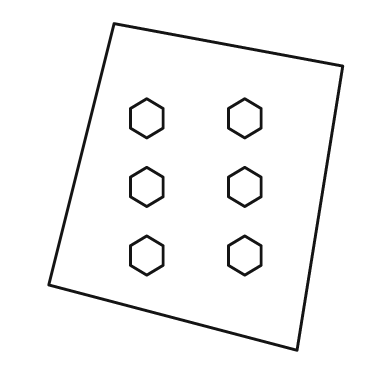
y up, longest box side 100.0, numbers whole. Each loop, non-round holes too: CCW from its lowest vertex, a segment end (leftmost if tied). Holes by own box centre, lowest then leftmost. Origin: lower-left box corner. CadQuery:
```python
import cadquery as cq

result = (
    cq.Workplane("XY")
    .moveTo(76.0, 0.0)
    .lineTo(90.0, 87.0)
    .lineTo(20.0, 100.0)
    .lineTo(0.0, 20.0)
    .close()
    .moveTo(30.0, 23.0)
    .lineTo(35.0, 26.0)
    .lineTo(35.0, 32.0)
    .lineTo(30.0, 35.0)
    .lineTo(25.0, 32.0)
    .lineTo(25.0, 26.0)
    .close()
    .moveTo(60.0, 23.0)
    .lineTo(65.0, 26.0)
    .lineTo(65.0, 32.0)
    .lineTo(60.0, 35.0)
    .lineTo(55.0, 32.0)
    .lineTo(55.0, 26.0)
    .close()
    .moveTo(30.0, 44.0)
    .lineTo(35.0, 47.0)
    .lineTo(35.0, 53.0)
    .lineTo(30.0, 56.0)
    .lineTo(25.0, 53.0)
    .lineTo(25.0, 47.0)
    .close()
    .moveTo(60.0, 44.0)
    .lineTo(65.0, 47.0)
    .lineTo(65.0, 53.0)
    .lineTo(60.0, 56.0)
    .lineTo(55.0, 53.0)
    .lineTo(55.0, 47.0)
    .close()
    .moveTo(30.0, 65.0)
    .lineTo(35.0, 68.0)
    .lineTo(35.0, 74.0)
    .lineTo(30.0, 77.0)
    .lineTo(25.0, 74.0)
    .lineTo(25.0, 68.0)
    .close()
    .moveTo(60.0, 65.0)
    .lineTo(65.0, 68.0)
    .lineTo(65.0, 74.0)
    .lineTo(60.0, 77.0)
    .lineTo(55.0, 74.0)
    .lineTo(55.0, 68.0)
    .close()
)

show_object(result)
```